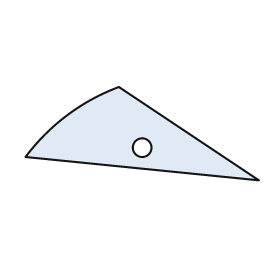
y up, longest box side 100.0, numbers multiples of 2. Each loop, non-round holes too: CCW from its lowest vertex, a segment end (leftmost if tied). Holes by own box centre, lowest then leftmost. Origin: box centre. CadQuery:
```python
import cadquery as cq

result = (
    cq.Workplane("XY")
    .moveTo(50.0, -20.0)
    .lineTo(-10.0, 20.0)
    .threePointArc((-32.0, 8.0), (-50.0, -10.0))
    .close()
    .moveTo(0.0, -6.0)
    .circle(4.0)
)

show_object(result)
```